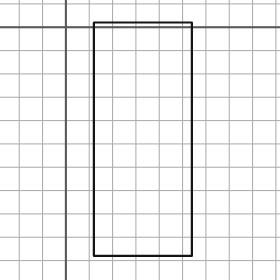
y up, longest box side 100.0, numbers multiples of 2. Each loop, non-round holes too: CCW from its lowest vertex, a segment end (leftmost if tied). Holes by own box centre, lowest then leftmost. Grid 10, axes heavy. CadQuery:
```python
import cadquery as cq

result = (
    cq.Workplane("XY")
    .moveTo(12.0, -98.0)
    .lineTo(54.0, -98.0)
    .lineTo(54.0, 2.0)
    .lineTo(12.0, 2.0)
    .close()
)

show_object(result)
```